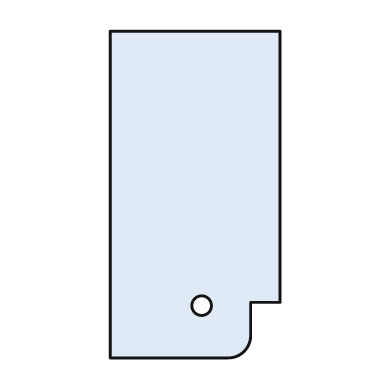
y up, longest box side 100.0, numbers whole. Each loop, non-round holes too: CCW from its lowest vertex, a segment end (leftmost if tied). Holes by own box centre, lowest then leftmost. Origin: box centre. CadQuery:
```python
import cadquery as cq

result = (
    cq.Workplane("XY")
    .moveTo(-26.0, -50.0)
    .lineTo(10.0, -50.0)
    .threePointArc((15.0, -48.0), (17.0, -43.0))
    .lineTo(17.0, -33.0)
    .lineTo(26.0, -33.0)
    .lineTo(26.0, 50.0)
    .lineTo(-26.0, 50.0)
    .close()
    .moveTo(2.0, -34.0)
    .circle(3.0)
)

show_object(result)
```